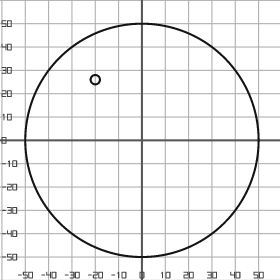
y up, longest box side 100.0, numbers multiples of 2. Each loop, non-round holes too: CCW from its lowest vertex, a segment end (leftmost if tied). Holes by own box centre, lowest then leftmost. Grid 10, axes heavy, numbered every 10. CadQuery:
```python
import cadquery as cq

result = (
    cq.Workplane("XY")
    .moveTo(0.0, 0.0)
    .circle(50.0)
    .moveTo(-20.0, 26.0)
    .circle(2.0)
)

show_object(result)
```